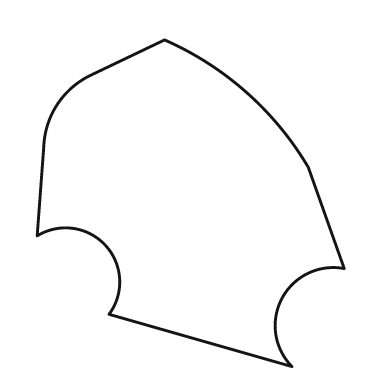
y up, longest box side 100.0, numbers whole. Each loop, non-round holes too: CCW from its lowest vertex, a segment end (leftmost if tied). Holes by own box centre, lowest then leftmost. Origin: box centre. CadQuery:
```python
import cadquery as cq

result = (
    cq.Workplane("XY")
    .moveTo(31.0, -50.0)
    .threePointArc((28.0, -29.0), (47.0, -20.0))
    .lineTo(36.0, 11.0)
    .threePointArc((17.0, 34.0), (-8.0, 50.0))
    .lineTo(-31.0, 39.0)
    .threePointArc((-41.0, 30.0), (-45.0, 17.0))
    .lineTo(-47.0, -10.0)
    .threePointArc((-26.0, -13.0), (-25.0, -34.0))
    .close()
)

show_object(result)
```